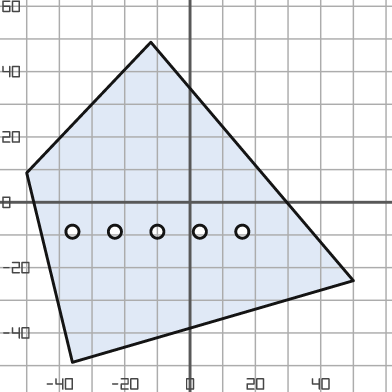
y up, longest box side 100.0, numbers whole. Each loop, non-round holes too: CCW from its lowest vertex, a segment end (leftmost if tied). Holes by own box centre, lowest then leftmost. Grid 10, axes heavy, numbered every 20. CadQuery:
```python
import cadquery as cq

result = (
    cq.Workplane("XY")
    .moveTo(-36.0, -49.0)
    .lineTo(50.0, -24.0)
    .lineTo(-12.0, 49.0)
    .lineTo(-50.0, 9.0)
    .close()
    .moveTo(-36.0, -9.0)
    .circle(2.0)
    .moveTo(-23.0, -9.0)
    .circle(2.0)
    .moveTo(-10.0, -9.0)
    .circle(2.0)
    .moveTo(3.0, -9.0)
    .circle(2.0)
    .moveTo(16.0, -9.0)
    .circle(2.0)
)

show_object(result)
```